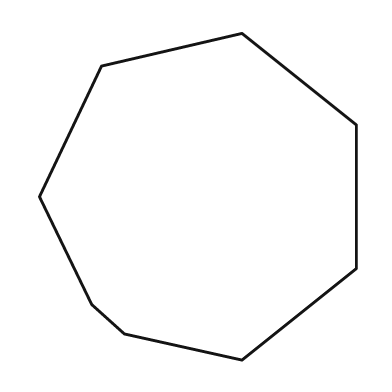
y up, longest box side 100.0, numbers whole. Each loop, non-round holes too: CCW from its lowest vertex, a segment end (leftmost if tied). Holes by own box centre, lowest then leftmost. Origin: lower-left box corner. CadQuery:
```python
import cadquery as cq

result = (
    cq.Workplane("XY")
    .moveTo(62.0, 0.0)
    .lineTo(97.0, 28.0)
    .lineTo(97.0, 72.0)
    .lineTo(62.0, 100.0)
    .lineTo(19.0, 90.0)
    .lineTo(0.0, 50.0)
    .lineTo(16.0, 17.0)
    .lineTo(26.0, 8.0)
    .close()
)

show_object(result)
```